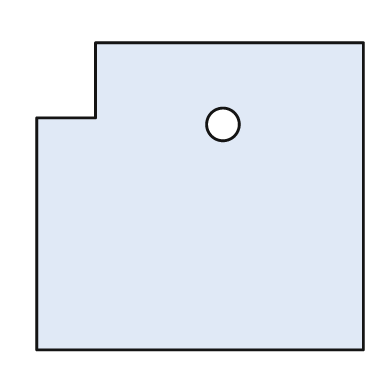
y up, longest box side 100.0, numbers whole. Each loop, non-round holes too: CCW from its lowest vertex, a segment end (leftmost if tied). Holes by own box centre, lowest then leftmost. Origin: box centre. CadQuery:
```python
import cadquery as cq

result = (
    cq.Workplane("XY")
    .moveTo(-50.0, -47.0)
    .lineTo(50.0, -47.0)
    .lineTo(50.0, 47.0)
    .lineTo(-32.0, 47.0)
    .lineTo(-32.0, 24.0)
    .lineTo(-50.0, 24.0)
    .close()
    .moveTo(7.0, 22.0)
    .circle(5.0)
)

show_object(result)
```